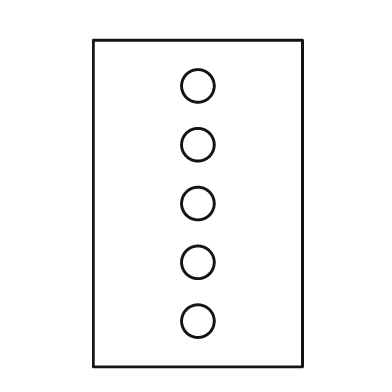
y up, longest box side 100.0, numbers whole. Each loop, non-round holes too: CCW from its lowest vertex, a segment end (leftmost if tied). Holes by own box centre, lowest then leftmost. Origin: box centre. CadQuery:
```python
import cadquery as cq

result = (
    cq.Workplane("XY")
    .moveTo(-32.0, -50.0)
    .lineTo(32.0, -50.0)
    .lineTo(32.0, 50.0)
    .lineTo(-32.0, 50.0)
    .close()
    .moveTo(0.0, -36.0)
    .circle(5.0)
    .moveTo(0.0, -18.0)
    .circle(5.0)
    .moveTo(0.0, 0.0)
    .circle(5.0)
    .moveTo(0.0, 18.0)
    .circle(5.0)
    .moveTo(0.0, 36.0)
    .circle(5.0)
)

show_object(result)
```